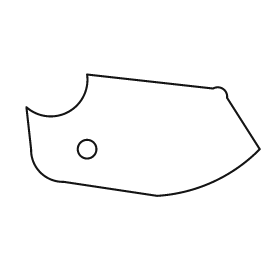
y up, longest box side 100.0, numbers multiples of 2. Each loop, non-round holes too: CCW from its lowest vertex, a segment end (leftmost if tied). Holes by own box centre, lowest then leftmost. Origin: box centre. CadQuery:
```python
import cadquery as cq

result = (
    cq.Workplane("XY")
    .moveTo(6.0, -26.0)
    .threePointArc((30.0, -20.0), (50.0, -6.0))
    .lineTo(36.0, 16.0)
    .threePointArc((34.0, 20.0), (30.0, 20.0))
    .lineTo(-24.0, 26.0)
    .threePointArc((-32.0, 10.0), (-50.0, 12.0))
    .lineTo(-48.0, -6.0)
    .threePointArc((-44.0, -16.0), (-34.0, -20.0))
    .close()
    .moveTo(-24.0, -6.0)
    .circle(4.0)
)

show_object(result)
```